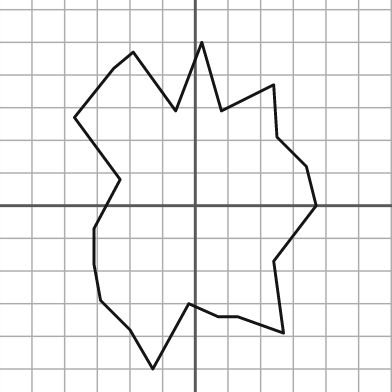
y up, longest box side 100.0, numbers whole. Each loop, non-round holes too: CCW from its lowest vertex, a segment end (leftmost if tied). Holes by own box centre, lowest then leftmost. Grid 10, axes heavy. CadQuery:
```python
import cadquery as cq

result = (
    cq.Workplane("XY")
    .moveTo(-13.0, -50.0)
    .lineTo(-2.0, -30.0)
    .lineTo(7.0, -34.0)
    .lineTo(13.0, -34.0)
    .lineTo(27.0, -39.0)
    .lineTo(24.0, -17.0)
    .lineTo(37.0, 0.0)
    .lineTo(34.0, 12.0)
    .lineTo(25.0, 21.0)
    .lineTo(24.0, 37.0)
    .lineTo(8.0, 29.0)
    .lineTo(2.0, 50.0)
    .lineTo(-6.0, 29.0)
    .lineTo(-19.0, 47.0)
    .lineTo(-25.0, 42.0)
    .lineTo(-37.0, 27.0)
    .lineTo(-23.0, 8.0)
    .lineTo(-31.0, -7.0)
    .lineTo(-31.0, -18.0)
    .lineTo(-29.0, -29.0)
    .lineTo(-20.0, -38.0)
    .close()
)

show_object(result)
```